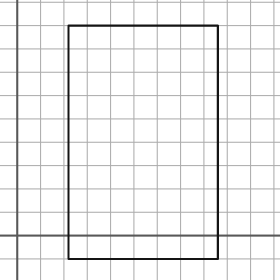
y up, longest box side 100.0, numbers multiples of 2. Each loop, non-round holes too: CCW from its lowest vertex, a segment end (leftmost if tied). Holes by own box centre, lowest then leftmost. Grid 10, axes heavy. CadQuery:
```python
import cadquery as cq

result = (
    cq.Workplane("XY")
    .moveTo(22.0, -10.0)
    .lineTo(86.0, -10.0)
    .lineTo(86.0, 90.0)
    .lineTo(22.0, 90.0)
    .close()
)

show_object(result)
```